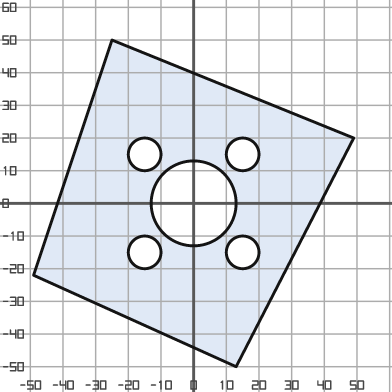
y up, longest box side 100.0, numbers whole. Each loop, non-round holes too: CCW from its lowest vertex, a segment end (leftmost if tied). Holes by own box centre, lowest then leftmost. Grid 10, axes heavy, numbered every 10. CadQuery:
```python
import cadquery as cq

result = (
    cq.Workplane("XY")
    .moveTo(13.0, -50.0)
    .lineTo(49.0, 20.0)
    .lineTo(-25.0, 50.0)
    .lineTo(-49.0, -22.0)
    .close()
    .moveTo(-15.0, -15.0)
    .circle(5.0)
    .moveTo(15.0, -15.0)
    .circle(5.0)
    .moveTo(0.0, 0.0)
    .circle(13.0)
    .moveTo(-15.0, 15.0)
    .circle(5.0)
    .moveTo(15.0, 15.0)
    .circle(5.0)
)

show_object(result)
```